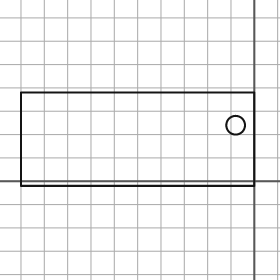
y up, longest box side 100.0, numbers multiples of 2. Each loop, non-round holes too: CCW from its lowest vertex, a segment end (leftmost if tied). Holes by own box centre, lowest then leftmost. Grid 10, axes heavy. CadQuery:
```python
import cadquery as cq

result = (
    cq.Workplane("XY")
    .moveTo(-100.0, -2.0)
    .lineTo(0.0, -2.0)
    .lineTo(0.0, 38.0)
    .lineTo(-100.0, 38.0)
    .close()
    .moveTo(-8.0, 24.0)
    .circle(4.0)
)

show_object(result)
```